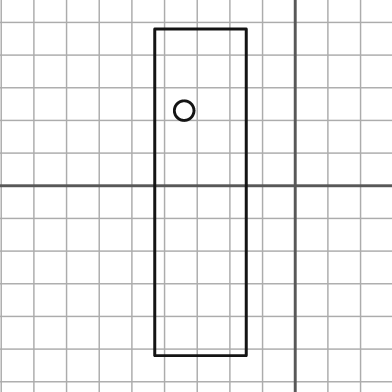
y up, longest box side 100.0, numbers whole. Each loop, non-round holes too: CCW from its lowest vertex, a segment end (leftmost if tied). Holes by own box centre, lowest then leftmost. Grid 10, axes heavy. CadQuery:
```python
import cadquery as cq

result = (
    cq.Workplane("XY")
    .moveTo(-43.0, -52.0)
    .lineTo(-15.0, -52.0)
    .lineTo(-15.0, 48.0)
    .lineTo(-43.0, 48.0)
    .close()
    .moveTo(-34.0, 23.0)
    .circle(3.0)
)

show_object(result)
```